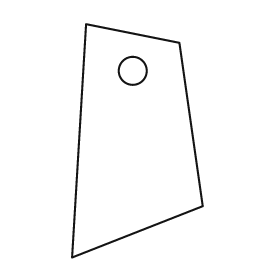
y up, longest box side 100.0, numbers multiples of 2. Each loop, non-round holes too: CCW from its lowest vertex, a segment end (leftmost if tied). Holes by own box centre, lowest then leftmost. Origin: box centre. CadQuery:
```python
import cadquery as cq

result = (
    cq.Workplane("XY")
    .moveTo(-28.0, -50.0)
    .lineTo(28.0, -28.0)
    .lineTo(18.0, 42.0)
    .lineTo(-22.0, 50.0)
    .close()
    .moveTo(-2.0, 30.0)
    .circle(6.0)
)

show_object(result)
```